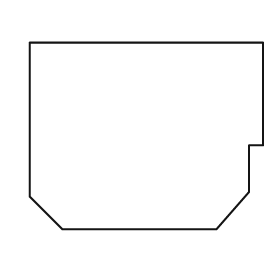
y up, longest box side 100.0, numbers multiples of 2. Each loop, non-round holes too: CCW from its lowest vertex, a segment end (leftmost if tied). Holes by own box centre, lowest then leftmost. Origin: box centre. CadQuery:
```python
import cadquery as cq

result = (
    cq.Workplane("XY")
    .moveTo(-36.0, -40.0)
    .lineTo(30.0, -40.0)
    .lineTo(44.0, -24.0)
    .lineTo(44.0, -4.0)
    .lineTo(50.0, -4.0)
    .lineTo(50.0, 40.0)
    .lineTo(-50.0, 40.0)
    .lineTo(-50.0, -26.0)
    .close()
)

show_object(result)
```